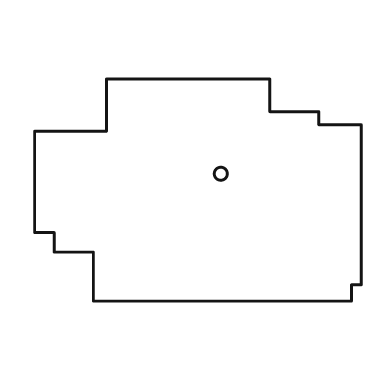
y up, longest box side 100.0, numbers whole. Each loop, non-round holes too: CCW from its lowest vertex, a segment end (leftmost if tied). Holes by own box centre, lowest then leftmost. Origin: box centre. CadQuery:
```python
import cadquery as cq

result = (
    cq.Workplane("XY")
    .moveTo(-32.0, -34.0)
    .lineTo(47.0, -34.0)
    .lineTo(47.0, -29.0)
    .lineTo(50.0, -29.0)
    .lineTo(50.0, 20.0)
    .lineTo(37.0, 20.0)
    .lineTo(37.0, 24.0)
    .lineTo(22.0, 24.0)
    .lineTo(22.0, 34.0)
    .lineTo(-28.0, 34.0)
    .lineTo(-28.0, 18.0)
    .lineTo(-50.0, 18.0)
    .lineTo(-50.0, -13.0)
    .lineTo(-44.0, -13.0)
    .lineTo(-44.0, -19.0)
    .lineTo(-32.0, -19.0)
    .close()
    .moveTo(7.0, 5.0)
    .circle(2.0)
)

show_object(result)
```